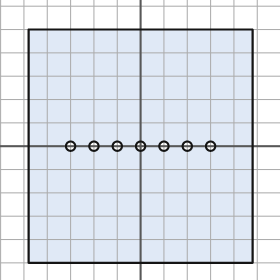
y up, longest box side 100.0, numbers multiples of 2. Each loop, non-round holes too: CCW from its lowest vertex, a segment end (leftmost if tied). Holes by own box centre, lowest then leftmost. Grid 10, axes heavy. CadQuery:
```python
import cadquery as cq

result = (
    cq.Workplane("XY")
    .moveTo(-48.0, -50.0)
    .lineTo(48.0, -50.0)
    .lineTo(48.0, 50.0)
    .lineTo(-48.0, 50.0)
    .close()
    .moveTo(-30.0, 0.0)
    .circle(2.0)
    .moveTo(-20.0, 0.0)
    .circle(2.0)
    .moveTo(-10.0, 0.0)
    .circle(2.0)
    .moveTo(0.0, 0.0)
    .circle(2.0)
    .moveTo(10.0, 0.0)
    .circle(2.0)
    .moveTo(20.0, 0.0)
    .circle(2.0)
    .moveTo(30.0, 0.0)
    .circle(2.0)
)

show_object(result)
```